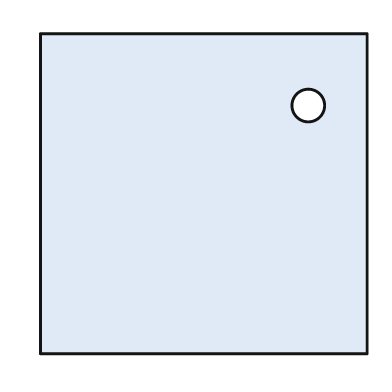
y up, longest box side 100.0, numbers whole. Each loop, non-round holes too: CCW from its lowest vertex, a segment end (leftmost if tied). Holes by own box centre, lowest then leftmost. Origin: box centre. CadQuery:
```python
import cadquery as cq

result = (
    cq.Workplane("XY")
    .moveTo(-50.0, -49.0)
    .lineTo(50.0, -49.0)
    .lineTo(50.0, 49.0)
    .lineTo(-50.0, 49.0)
    .close()
    .moveTo(32.0, 27.0)
    .circle(5.0)
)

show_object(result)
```